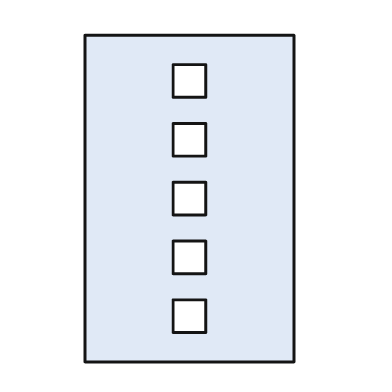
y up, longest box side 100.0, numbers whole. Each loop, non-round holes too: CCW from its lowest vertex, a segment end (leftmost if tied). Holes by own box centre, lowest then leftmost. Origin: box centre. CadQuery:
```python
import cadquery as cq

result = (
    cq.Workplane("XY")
    .moveTo(-32.0, -50.0)
    .lineTo(32.0, -50.0)
    .lineTo(32.0, 50.0)
    .lineTo(-32.0, 50.0)
    .close()
    .moveTo(-5.0, -41.0)
    .lineTo(5.0, -41.0)
    .lineTo(5.0, -31.0)
    .lineTo(-5.0, -31.0)
    .close()
    .moveTo(-5.0, -23.0)
    .lineTo(5.0, -23.0)
    .lineTo(5.0, -13.0)
    .lineTo(-5.0, -13.0)
    .close()
    .moveTo(-5.0, -5.0)
    .lineTo(5.0, -5.0)
    .lineTo(5.0, 5.0)
    .lineTo(-5.0, 5.0)
    .close()
    .moveTo(-5.0, 13.0)
    .lineTo(5.0, 13.0)
    .lineTo(5.0, 23.0)
    .lineTo(-5.0, 23.0)
    .close()
    .moveTo(-5.0, 31.0)
    .lineTo(5.0, 31.0)
    .lineTo(5.0, 41.0)
    .lineTo(-5.0, 41.0)
    .close()
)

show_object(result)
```